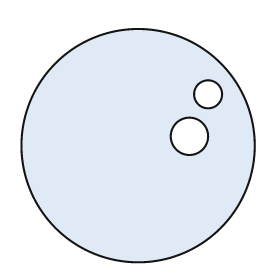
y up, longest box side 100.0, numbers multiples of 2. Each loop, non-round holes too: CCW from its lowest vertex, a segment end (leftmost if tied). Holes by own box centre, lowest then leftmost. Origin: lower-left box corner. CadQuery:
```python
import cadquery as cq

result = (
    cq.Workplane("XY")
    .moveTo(50.0, 50.0)
    .circle(50.0)
    .moveTo(72.0, 54.0)
    .circle(8.0)
    .moveTo(80.0, 72.0)
    .circle(6.0)
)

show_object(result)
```